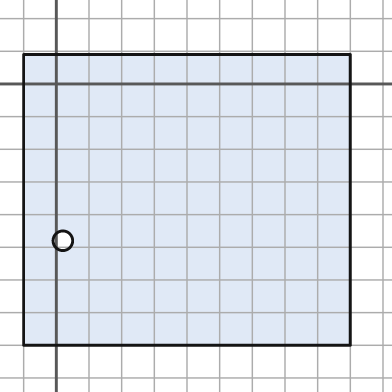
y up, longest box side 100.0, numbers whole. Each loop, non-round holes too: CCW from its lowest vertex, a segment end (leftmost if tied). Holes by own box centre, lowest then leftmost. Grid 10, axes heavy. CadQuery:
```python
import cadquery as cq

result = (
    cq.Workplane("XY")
    .moveTo(-10.0, -80.0)
    .lineTo(90.0, -80.0)
    .lineTo(90.0, 9.0)
    .lineTo(-10.0, 9.0)
    .close()
    .moveTo(2.0, -48.0)
    .circle(3.0)
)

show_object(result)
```